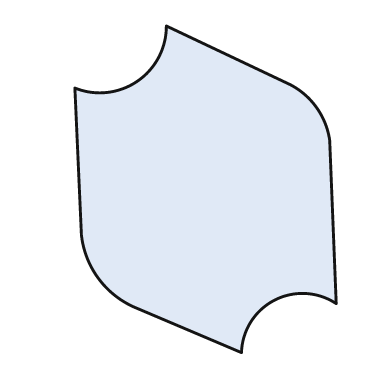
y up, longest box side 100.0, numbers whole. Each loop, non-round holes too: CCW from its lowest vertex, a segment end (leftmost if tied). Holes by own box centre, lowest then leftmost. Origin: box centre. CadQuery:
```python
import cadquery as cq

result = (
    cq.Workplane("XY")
    .moveTo(11.0, -50.0)
    .threePointArc((21.0, -34.0), (40.0, -35.0))
    .lineTo(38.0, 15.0)
    .threePointArc((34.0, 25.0), (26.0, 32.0))
    .lineTo(-12.0, 50.0)
    .threePointArc((-21.0, 33.0), (-40.0, 31.0))
    .lineTo(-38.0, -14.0)
    .threePointArc((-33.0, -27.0), (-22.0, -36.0))
    .close()
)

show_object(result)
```